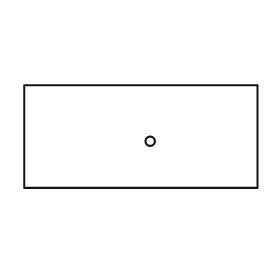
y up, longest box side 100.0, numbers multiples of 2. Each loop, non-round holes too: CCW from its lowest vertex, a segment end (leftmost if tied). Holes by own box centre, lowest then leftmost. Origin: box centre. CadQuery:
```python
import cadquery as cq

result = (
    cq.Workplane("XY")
    .moveTo(-50.0, -22.0)
    .lineTo(50.0, -22.0)
    .lineTo(50.0, 22.0)
    .lineTo(-50.0, 22.0)
    .close()
    .moveTo(4.0, -2.0)
    .circle(2.0)
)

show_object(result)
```